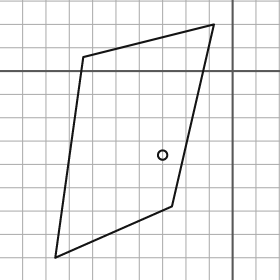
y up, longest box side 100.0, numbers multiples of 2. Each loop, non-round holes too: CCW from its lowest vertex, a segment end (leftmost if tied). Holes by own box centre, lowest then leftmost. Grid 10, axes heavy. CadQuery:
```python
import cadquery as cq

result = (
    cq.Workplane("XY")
    .moveTo(-76.0, -80.0)
    .lineTo(-26.0, -58.0)
    .lineTo(-8.0, 20.0)
    .lineTo(-64.0, 6.0)
    .close()
    .moveTo(-30.0, -36.0)
    .circle(2.0)
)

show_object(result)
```